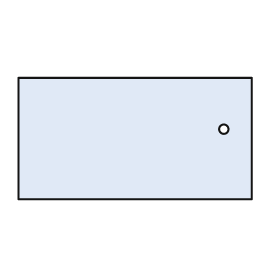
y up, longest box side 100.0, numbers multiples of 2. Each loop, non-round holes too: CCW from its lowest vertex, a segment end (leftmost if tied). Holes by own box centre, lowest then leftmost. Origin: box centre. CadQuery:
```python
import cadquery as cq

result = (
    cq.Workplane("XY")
    .moveTo(-50.0, -26.0)
    .lineTo(50.0, -26.0)
    .lineTo(50.0, 26.0)
    .lineTo(-50.0, 26.0)
    .close()
    .moveTo(38.0, 4.0)
    .circle(2.0)
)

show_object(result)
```